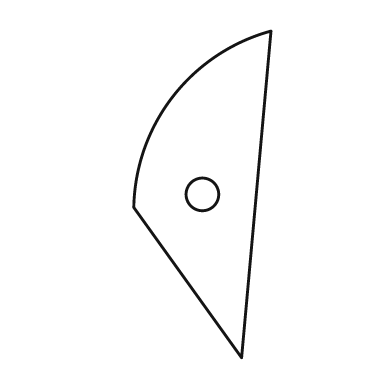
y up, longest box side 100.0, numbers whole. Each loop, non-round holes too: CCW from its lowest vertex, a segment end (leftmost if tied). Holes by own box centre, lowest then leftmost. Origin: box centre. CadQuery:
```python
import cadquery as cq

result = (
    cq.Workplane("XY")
    .moveTo(12.0, -50.0)
    .lineTo(21.0, 50.0)
    .threePointArc((-9.0, 30.0), (-21.0, -4.0))
    .close()
    .moveTo(0.0, 0.0)
    .circle(5.0)
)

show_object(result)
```